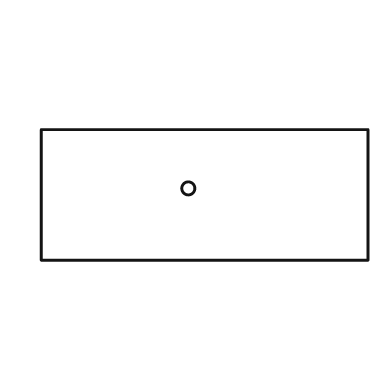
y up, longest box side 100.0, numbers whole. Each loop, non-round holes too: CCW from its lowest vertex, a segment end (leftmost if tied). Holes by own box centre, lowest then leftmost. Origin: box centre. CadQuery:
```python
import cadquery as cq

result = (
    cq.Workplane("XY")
    .moveTo(-50.0, -20.0)
    .lineTo(50.0, -20.0)
    .lineTo(50.0, 20.0)
    .lineTo(-50.0, 20.0)
    .close()
    .moveTo(-5.0, 2.0)
    .circle(2.0)
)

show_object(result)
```